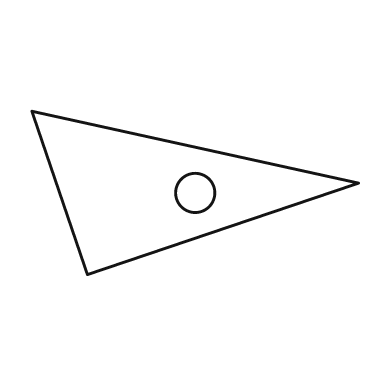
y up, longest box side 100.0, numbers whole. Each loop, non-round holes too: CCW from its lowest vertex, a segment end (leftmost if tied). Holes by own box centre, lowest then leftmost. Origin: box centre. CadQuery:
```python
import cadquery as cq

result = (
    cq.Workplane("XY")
    .moveTo(-33.0, -25.0)
    .lineTo(50.0, 3.0)
    .lineTo(-50.0, 25.0)
    .close()
    .moveTo(0.0, 0.0)
    .circle(6.0)
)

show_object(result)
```